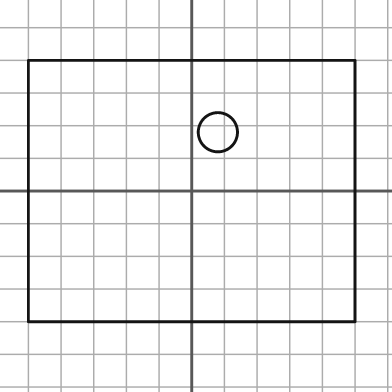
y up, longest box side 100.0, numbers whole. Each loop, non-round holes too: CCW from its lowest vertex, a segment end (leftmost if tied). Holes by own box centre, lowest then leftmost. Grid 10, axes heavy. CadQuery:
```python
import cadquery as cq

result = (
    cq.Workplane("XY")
    .moveTo(-50.0, -40.0)
    .lineTo(50.0, -40.0)
    .lineTo(50.0, 40.0)
    .lineTo(-50.0, 40.0)
    .close()
    .moveTo(8.0, 18.0)
    .circle(6.0)
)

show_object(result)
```